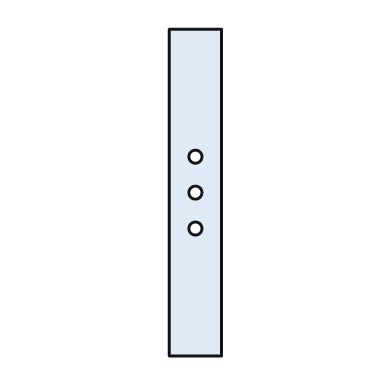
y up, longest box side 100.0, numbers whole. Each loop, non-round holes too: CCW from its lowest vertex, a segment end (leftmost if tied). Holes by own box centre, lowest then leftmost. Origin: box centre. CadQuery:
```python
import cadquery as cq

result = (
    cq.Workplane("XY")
    .moveTo(-8.0, -50.0)
    .lineTo(8.0, -50.0)
    .lineTo(8.0, 50.0)
    .lineTo(-8.0, 50.0)
    .close()
    .moveTo(0.0, -11.0)
    .circle(2.0)
    .moveTo(0.0, 0.0)
    .circle(2.0)
    .moveTo(0.0, 11.0)
    .circle(2.0)
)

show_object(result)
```